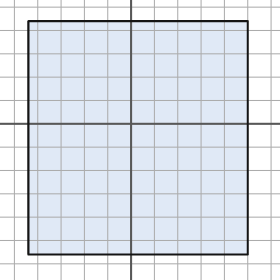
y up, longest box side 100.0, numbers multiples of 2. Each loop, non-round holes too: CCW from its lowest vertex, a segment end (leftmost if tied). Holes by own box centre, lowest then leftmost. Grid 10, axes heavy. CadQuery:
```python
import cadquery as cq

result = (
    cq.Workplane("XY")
    .moveTo(-44.0, -56.0)
    .lineTo(50.0, -56.0)
    .lineTo(50.0, 44.0)
    .lineTo(-44.0, 44.0)
    .close()
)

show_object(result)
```